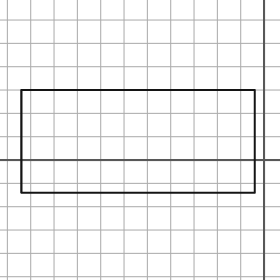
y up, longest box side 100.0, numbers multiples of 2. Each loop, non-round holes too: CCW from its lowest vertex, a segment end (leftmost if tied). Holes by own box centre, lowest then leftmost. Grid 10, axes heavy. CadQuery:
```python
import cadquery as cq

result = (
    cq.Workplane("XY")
    .moveTo(-104.0, -14.0)
    .lineTo(-4.0, -14.0)
    .lineTo(-4.0, 30.0)
    .lineTo(-104.0, 30.0)
    .close()
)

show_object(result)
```